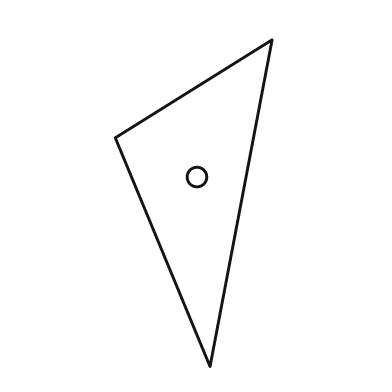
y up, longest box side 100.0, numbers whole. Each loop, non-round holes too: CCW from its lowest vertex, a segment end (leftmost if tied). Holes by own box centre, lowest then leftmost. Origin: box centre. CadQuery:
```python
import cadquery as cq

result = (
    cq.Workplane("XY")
    .moveTo(5.0, -50.0)
    .lineTo(24.0, 50.0)
    .lineTo(-24.0, 20.0)
    .close()
    .moveTo(1.0, 8.0)
    .circle(3.0)
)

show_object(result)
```